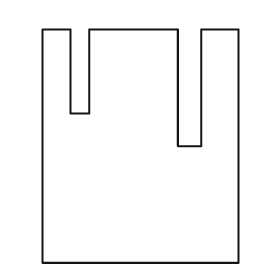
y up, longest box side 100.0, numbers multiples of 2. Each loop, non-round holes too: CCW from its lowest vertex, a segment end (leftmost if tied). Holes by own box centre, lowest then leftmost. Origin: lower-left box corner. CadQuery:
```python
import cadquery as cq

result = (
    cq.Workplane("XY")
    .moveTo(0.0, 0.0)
    .lineTo(84.0, 0.0)
    .lineTo(84.0, 100.0)
    .lineTo(68.0, 100.0)
    .lineTo(68.0, 50.0)
    .lineTo(58.0, 50.0)
    .lineTo(58.0, 100.0)
    .lineTo(20.0, 100.0)
    .lineTo(20.0, 64.0)
    .lineTo(12.0, 64.0)
    .lineTo(12.0, 100.0)
    .lineTo(0.0, 100.0)
    .close()
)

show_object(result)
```